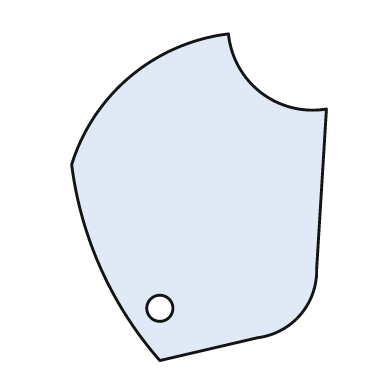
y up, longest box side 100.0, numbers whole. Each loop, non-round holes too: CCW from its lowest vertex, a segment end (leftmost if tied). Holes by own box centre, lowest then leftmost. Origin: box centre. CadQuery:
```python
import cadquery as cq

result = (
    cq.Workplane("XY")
    .moveTo(-12.0, -50.0)
    .lineTo(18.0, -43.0)
    .threePointArc((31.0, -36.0), (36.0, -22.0))
    .lineTo(39.0, 27.0)
    .threePointArc((19.0, 32.0), (9.0, 50.0))
    .threePointArc((-21.0, 37.0), (-39.0, 10.0))
    .threePointArc((-30.0, -22.0), (-12.0, -50.0))
    .close()
    .moveTo(-12.0, -34.0)
    .circle(4.0)
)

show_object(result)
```